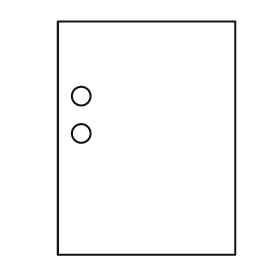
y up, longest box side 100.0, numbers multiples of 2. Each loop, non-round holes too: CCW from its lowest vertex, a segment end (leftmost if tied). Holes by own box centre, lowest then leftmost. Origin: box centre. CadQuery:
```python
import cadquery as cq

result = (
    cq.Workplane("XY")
    .moveTo(-38.0, -50.0)
    .lineTo(38.0, -50.0)
    .lineTo(38.0, 50.0)
    .lineTo(-38.0, 50.0)
    .close()
    .moveTo(-28.0, 2.0)
    .circle(4.0)
    .moveTo(-28.0, 18.0)
    .circle(4.0)
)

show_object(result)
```